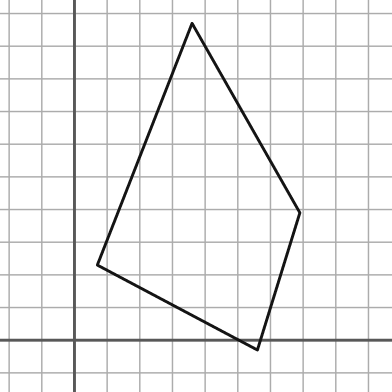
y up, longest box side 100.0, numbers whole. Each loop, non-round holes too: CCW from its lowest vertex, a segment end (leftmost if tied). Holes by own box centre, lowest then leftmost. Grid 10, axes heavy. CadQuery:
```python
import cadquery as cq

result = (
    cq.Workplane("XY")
    .moveTo(56.0, -3.0)
    .lineTo(69.0, 39.0)
    .lineTo(36.0, 97.0)
    .lineTo(7.0, 23.0)
    .close()
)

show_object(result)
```